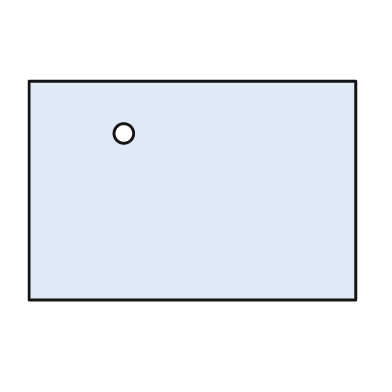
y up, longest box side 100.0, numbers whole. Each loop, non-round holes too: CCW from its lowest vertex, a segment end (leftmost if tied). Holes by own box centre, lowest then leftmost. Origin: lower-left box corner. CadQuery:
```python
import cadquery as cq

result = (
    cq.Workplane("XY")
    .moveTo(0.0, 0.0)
    .lineTo(100.0, 0.0)
    .lineTo(100.0, 67.0)
    .lineTo(0.0, 67.0)
    .close()
    .moveTo(29.0, 51.0)
    .circle(3.0)
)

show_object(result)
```